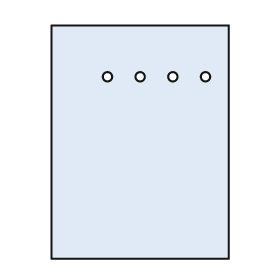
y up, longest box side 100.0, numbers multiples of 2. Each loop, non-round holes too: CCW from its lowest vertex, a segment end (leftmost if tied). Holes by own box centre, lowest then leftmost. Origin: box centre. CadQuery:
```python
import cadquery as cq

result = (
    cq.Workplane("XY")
    .moveTo(-38.0, -50.0)
    .lineTo(38.0, -50.0)
    .lineTo(38.0, 50.0)
    .lineTo(-38.0, 50.0)
    .close()
    .moveTo(-14.0, 28.0)
    .circle(2.0)
    .moveTo(0.0, 28.0)
    .circle(2.0)
    .moveTo(14.0, 28.0)
    .circle(2.0)
    .moveTo(28.0, 28.0)
    .circle(2.0)
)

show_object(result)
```